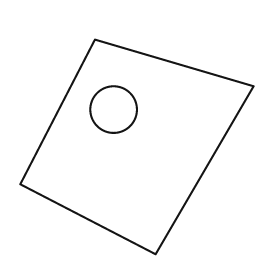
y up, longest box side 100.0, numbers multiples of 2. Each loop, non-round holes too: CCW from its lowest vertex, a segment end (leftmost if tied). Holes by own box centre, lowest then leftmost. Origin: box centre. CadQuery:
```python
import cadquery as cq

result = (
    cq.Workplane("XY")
    .moveTo(8.0, -46.0)
    .lineTo(50.0, 26.0)
    .lineTo(-18.0, 46.0)
    .lineTo(-50.0, -16.0)
    .close()
    .moveTo(-10.0, 16.0)
    .circle(10.0)
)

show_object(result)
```